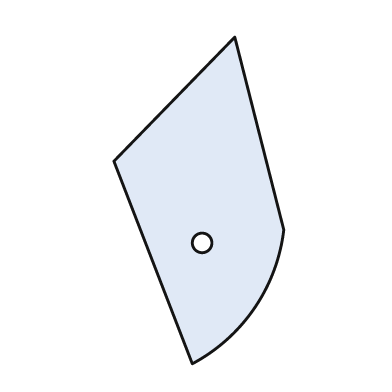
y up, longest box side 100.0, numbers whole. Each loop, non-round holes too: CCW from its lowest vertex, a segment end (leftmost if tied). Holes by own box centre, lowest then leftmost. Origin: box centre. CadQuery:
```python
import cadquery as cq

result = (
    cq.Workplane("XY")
    .moveTo(-2.0, -50.0)
    .threePointArc((17.0, -33.0), (26.0, -9.0))
    .lineTo(11.0, 50.0)
    .lineTo(-26.0, 12.0)
    .close()
    .moveTo(1.0, -13.0)
    .circle(3.0)
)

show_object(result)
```